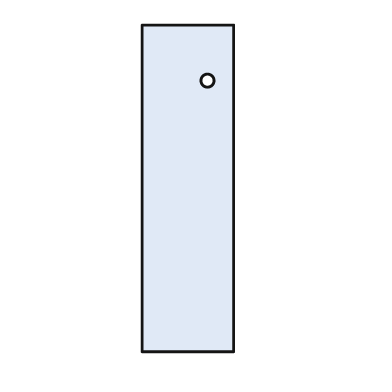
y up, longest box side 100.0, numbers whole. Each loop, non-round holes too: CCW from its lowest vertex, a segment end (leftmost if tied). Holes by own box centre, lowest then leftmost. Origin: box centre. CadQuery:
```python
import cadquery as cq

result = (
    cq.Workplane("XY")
    .moveTo(-14.0, -50.0)
    .lineTo(14.0, -50.0)
    .lineTo(14.0, 50.0)
    .lineTo(-14.0, 50.0)
    .close()
    .moveTo(6.0, 33.0)
    .circle(2.0)
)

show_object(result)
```